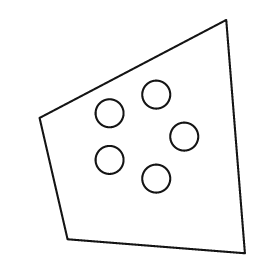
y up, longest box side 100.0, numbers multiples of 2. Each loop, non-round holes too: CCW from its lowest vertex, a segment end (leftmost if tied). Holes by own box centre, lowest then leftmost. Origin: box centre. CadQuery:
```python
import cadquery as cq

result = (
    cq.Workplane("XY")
    .moveTo(44.0, -50.0)
    .lineTo(36.0, 50.0)
    .lineTo(-44.0, 8.0)
    .lineTo(-32.0, -44.0)
    .close()
    .moveTo(6.0, -18.0)
    .circle(6.0)
    .moveTo(-14.0, -10.0)
    .circle(6.0)
    .moveTo(18.0, 0.0)
    .circle(6.0)
    .moveTo(-14.0, 10.0)
    .circle(6.0)
    .moveTo(6.0, 18.0)
    .circle(6.0)
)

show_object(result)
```